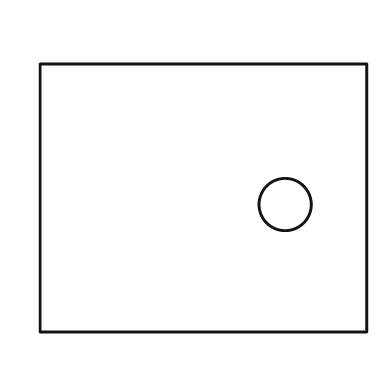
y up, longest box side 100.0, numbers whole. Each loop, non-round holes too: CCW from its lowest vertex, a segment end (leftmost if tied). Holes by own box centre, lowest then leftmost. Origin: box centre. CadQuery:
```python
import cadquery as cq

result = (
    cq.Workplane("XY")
    .moveTo(-50.0, -41.0)
    .lineTo(50.0, -41.0)
    .lineTo(50.0, 41.0)
    .lineTo(-50.0, 41.0)
    .close()
    .moveTo(25.0, -2.0)
    .circle(8.0)
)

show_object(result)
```